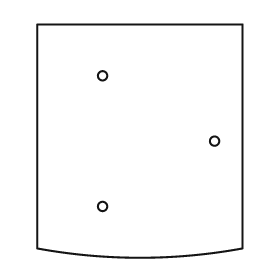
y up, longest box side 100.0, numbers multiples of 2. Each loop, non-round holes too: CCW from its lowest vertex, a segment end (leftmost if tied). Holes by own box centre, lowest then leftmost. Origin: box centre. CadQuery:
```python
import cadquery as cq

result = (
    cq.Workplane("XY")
    .moveTo(-44.0, -46.0)
    .threePointArc((0.0, -50.0), (44.0, -46.0))
    .lineTo(44.0, 50.0)
    .lineTo(-44.0, 50.0)
    .close()
    .moveTo(-16.0, -28.0)
    .circle(2.0)
    .moveTo(32.0, 0.0)
    .circle(2.0)
    .moveTo(-16.0, 28.0)
    .circle(2.0)
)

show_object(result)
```